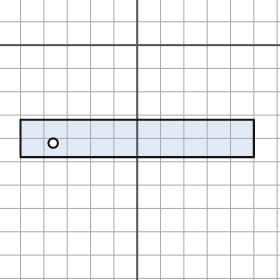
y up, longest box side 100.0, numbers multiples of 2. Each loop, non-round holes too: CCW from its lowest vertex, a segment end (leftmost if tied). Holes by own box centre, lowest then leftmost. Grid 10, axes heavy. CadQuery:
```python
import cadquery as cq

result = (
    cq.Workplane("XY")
    .moveTo(-50.0, -48.0)
    .lineTo(50.0, -48.0)
    .lineTo(50.0, -32.0)
    .lineTo(-50.0, -32.0)
    .close()
    .moveTo(-36.0, -42.0)
    .circle(2.0)
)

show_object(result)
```